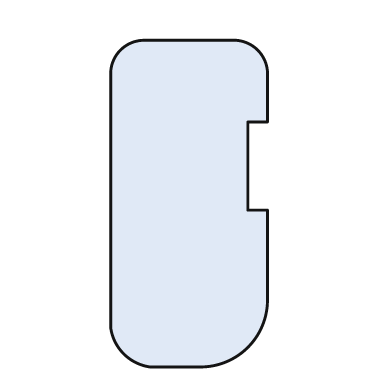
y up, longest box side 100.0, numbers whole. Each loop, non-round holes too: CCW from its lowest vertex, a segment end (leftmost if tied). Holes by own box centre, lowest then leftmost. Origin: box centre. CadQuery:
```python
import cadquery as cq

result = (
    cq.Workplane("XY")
    .moveTo(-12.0, -50.0)
    .lineTo(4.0, -50.0)
    .threePointArc((18.0, -44.0), (24.0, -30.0))
    .lineTo(24.0, -2.0)
    .lineTo(18.0, -2.0)
    .lineTo(18.0, 25.0)
    .lineTo(24.0, 25.0)
    .lineTo(24.0, 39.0)
    .threePointArc((21.0, 47.0), (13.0, 50.0))
    .lineTo(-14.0, 50.0)
    .threePointArc((-21.0, 47.0), (-24.0, 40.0))
    .lineTo(-24.0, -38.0)
    .threePointArc((-20.0, -46.0), (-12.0, -50.0))
    .close()
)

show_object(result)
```